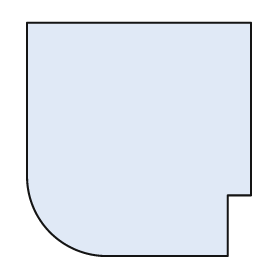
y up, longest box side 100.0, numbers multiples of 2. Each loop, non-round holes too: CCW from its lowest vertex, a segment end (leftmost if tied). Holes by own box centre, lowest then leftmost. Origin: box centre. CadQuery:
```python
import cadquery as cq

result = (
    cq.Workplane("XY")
    .moveTo(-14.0, -50.0)
    .lineTo(38.0, -50.0)
    .lineTo(38.0, -24.0)
    .lineTo(48.0, -24.0)
    .lineTo(48.0, 50.0)
    .lineTo(-48.0, 50.0)
    .lineTo(-48.0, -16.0)
    .threePointArc((-38.0, -40.0), (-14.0, -50.0))
    .close()
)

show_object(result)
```